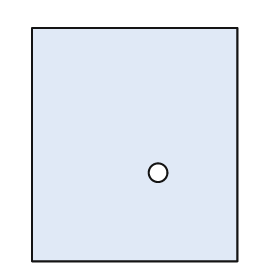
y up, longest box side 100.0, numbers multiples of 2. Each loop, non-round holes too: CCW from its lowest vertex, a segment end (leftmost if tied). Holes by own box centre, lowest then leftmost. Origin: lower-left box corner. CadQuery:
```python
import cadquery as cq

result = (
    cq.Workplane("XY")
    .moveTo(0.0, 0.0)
    .lineTo(88.0, 0.0)
    .lineTo(88.0, 100.0)
    .lineTo(0.0, 100.0)
    .close()
    .moveTo(54.0, 38.0)
    .circle(4.0)
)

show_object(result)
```